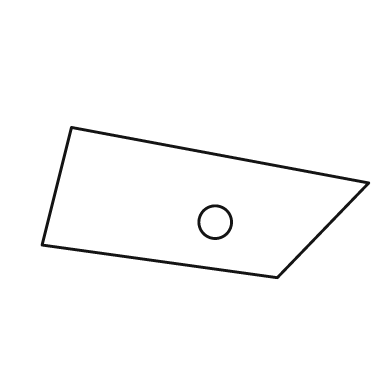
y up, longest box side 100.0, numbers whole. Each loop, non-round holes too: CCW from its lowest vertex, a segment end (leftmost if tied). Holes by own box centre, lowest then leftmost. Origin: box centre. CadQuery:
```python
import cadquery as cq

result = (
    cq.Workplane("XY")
    .moveTo(22.0, -23.0)
    .lineTo(50.0, 6.0)
    .lineTo(-41.0, 23.0)
    .lineTo(-50.0, -13.0)
    .close()
    .moveTo(3.0, -6.0)
    .circle(5.0)
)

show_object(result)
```